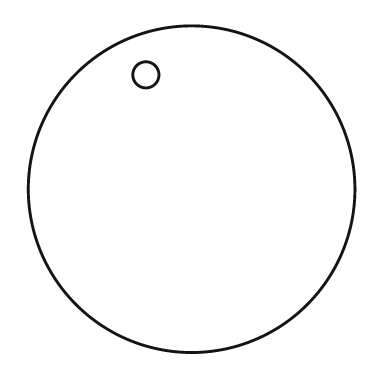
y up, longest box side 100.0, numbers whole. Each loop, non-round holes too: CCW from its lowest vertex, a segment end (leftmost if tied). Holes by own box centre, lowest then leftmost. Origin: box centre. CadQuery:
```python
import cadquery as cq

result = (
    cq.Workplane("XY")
    .moveTo(0.0, 0.0)
    .circle(50.0)
    .moveTo(-14.0, 35.0)
    .circle(4.0)
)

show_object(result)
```